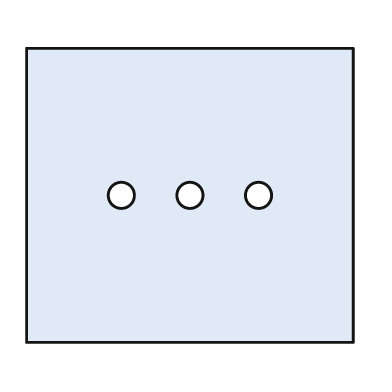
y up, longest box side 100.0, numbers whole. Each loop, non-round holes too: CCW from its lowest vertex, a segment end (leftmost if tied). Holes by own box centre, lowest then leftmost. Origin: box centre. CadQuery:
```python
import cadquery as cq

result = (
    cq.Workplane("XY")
    .moveTo(-50.0, -45.0)
    .lineTo(50.0, -45.0)
    .lineTo(50.0, 45.0)
    .lineTo(-50.0, 45.0)
    .close()
    .moveTo(-21.0, 0.0)
    .circle(4.0)
    .moveTo(0.0, 0.0)
    .circle(4.0)
    .moveTo(21.0, 0.0)
    .circle(4.0)
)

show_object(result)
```